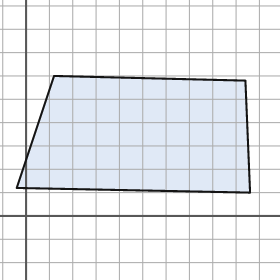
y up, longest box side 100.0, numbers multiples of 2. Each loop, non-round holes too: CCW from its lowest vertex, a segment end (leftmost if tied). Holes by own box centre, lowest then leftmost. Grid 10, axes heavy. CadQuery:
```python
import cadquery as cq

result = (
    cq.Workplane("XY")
    .moveTo(96.0, 10.0)
    .lineTo(94.0, 58.0)
    .lineTo(12.0, 60.0)
    .lineTo(-4.0, 12.0)
    .close()
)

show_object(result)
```